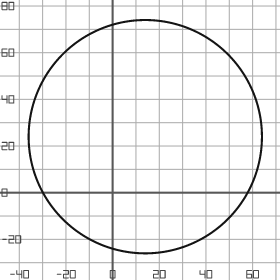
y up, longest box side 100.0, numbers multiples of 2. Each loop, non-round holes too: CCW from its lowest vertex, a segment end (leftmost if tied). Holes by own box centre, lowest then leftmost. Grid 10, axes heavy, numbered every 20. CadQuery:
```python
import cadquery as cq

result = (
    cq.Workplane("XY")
    .moveTo(14.0, 24.0)
    .circle(50.0)
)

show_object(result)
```